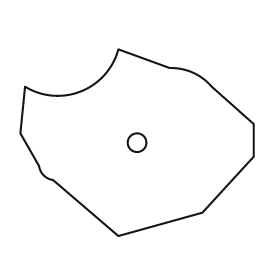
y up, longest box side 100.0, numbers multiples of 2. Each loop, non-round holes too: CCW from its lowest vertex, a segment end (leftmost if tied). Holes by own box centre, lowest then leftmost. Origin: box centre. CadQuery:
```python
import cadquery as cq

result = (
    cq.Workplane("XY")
    .moveTo(-8.0, -40.0)
    .lineTo(28.0, -30.0)
    .lineTo(50.0, -6.0)
    .lineTo(50.0, 8.0)
    .lineTo(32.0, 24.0)
    .threePointArc((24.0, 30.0), (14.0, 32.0))
    .lineTo(-8.0, 40.0)
    .threePointArc((-24.0, 22.0), (-48.0, 24.0))
    .lineTo(-50.0, 4.0)
    .lineTo(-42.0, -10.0)
    .threePointArc((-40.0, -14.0), (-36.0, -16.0))
    .close()
    .moveTo(0.0, 0.0)
    .circle(4.0)
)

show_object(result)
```